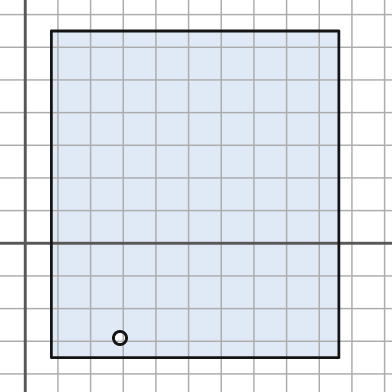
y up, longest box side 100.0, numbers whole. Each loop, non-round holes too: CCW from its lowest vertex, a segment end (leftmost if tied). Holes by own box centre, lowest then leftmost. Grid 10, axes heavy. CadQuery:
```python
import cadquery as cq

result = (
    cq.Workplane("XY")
    .moveTo(8.0, -35.0)
    .lineTo(96.0, -35.0)
    .lineTo(96.0, 65.0)
    .lineTo(8.0, 65.0)
    .close()
    .moveTo(29.0, -29.0)
    .circle(2.0)
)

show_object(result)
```